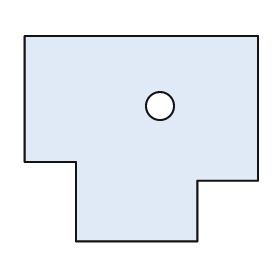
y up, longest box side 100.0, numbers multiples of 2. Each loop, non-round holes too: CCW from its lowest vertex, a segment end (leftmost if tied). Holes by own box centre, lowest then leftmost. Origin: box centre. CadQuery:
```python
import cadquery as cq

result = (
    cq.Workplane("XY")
    .moveTo(-28.0, -44.0)
    .lineTo(24.0, -44.0)
    .lineTo(24.0, -18.0)
    .lineTo(50.0, -18.0)
    .lineTo(50.0, 44.0)
    .lineTo(-50.0, 44.0)
    .lineTo(-50.0, -10.0)
    .lineTo(-28.0, -10.0)
    .close()
    .moveTo(8.0, 14.0)
    .circle(6.0)
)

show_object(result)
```